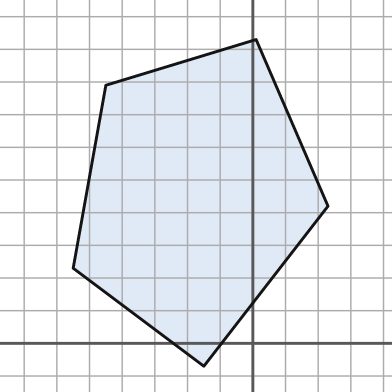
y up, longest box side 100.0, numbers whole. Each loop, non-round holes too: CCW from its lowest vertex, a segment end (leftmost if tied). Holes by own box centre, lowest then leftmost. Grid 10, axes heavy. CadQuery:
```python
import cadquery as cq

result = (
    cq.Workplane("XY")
    .moveTo(-15.0, -7.0)
    .lineTo(23.0, 42.0)
    .lineTo(1.0, 93.0)
    .lineTo(-45.0, 79.0)
    .lineTo(-55.0, 23.0)
    .close()
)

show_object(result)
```